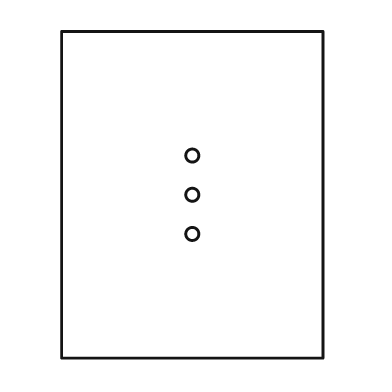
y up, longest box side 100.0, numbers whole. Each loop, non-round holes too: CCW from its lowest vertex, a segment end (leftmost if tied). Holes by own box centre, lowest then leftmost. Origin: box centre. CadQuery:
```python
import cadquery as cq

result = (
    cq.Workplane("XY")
    .moveTo(-40.0, -50.0)
    .lineTo(40.0, -50.0)
    .lineTo(40.0, 50.0)
    .lineTo(-40.0, 50.0)
    .close()
    .moveTo(0.0, -12.0)
    .circle(2.0)
    .moveTo(0.0, 0.0)
    .circle(2.0)
    .moveTo(0.0, 12.0)
    .circle(2.0)
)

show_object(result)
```